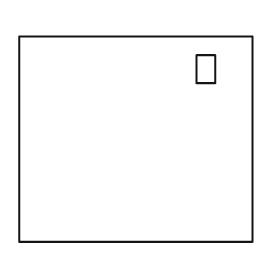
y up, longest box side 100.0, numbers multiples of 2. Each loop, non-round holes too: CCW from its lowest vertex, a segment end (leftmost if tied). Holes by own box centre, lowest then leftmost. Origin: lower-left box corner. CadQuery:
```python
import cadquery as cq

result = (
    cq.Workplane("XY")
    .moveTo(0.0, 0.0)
    .lineTo(100.0, 0.0)
    .lineTo(100.0, 88.0)
    .lineTo(0.0, 88.0)
    .close()
    .moveTo(76.0, 68.0)
    .lineTo(84.0, 68.0)
    .lineTo(84.0, 80.0)
    .lineTo(76.0, 80.0)
    .close()
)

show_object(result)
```